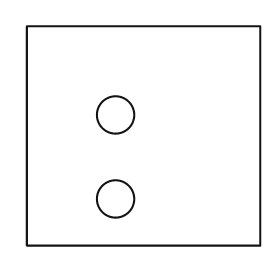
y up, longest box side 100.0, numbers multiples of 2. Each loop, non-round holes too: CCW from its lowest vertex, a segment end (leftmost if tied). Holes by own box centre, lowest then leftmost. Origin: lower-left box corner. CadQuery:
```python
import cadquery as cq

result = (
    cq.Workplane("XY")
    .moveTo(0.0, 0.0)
    .lineTo(100.0, 0.0)
    .lineTo(100.0, 94.0)
    .lineTo(0.0, 94.0)
    .close()
    .moveTo(38.0, 20.0)
    .circle(8.0)
    .moveTo(38.0, 56.0)
    .circle(8.0)
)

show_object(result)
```